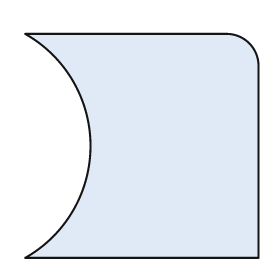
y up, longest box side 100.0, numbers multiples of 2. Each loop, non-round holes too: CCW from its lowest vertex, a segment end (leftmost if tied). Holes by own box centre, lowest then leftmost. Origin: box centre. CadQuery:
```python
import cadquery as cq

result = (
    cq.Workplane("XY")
    .moveTo(-50.0, -48.0)
    .lineTo(50.0, -48.0)
    .lineTo(50.0, 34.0)
    .threePointArc((46.0, 44.0), (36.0, 48.0))
    .lineTo(-50.0, 48.0)
    .threePointArc((-22.0, 0.0), (-50.0, -48.0))
    .close()
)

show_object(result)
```